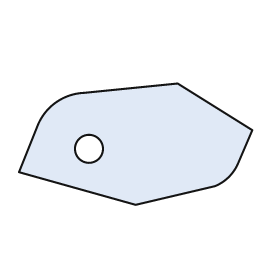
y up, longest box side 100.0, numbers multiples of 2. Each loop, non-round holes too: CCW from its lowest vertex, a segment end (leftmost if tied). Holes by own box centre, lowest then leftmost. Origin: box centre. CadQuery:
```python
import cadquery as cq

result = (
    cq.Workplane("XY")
    .moveTo(0.0, -26.0)
    .lineTo(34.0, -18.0)
    .threePointArc((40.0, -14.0), (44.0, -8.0))
    .lineTo(50.0, 6.0)
    .lineTo(18.0, 26.0)
    .lineTo(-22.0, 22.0)
    .threePointArc((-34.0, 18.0), (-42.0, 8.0))
    .lineTo(-50.0, -12.0)
    .close()
    .moveTo(-20.0, -2.0)
    .circle(6.0)
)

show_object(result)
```